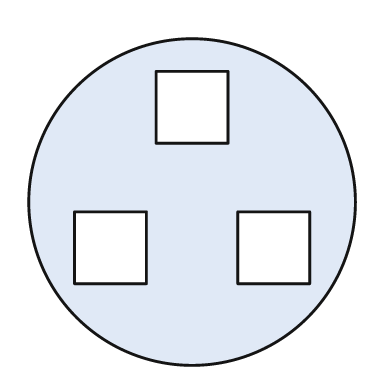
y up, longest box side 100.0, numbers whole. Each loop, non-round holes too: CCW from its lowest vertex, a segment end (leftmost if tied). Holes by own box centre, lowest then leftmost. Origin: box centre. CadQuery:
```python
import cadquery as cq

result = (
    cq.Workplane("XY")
    .moveTo(0.0, 0.0)
    .circle(50.0)
    .moveTo(-36.0, -25.0)
    .lineTo(-14.0, -25.0)
    .lineTo(-14.0, -3.0)
    .lineTo(-36.0, -3.0)
    .close()
    .moveTo(14.0, -25.0)
    .lineTo(36.0, -25.0)
    .lineTo(36.0, -3.0)
    .lineTo(14.0, -3.0)
    .close()
    .moveTo(-11.0, 18.0)
    .lineTo(11.0, 18.0)
    .lineTo(11.0, 40.0)
    .lineTo(-11.0, 40.0)
    .close()
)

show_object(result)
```